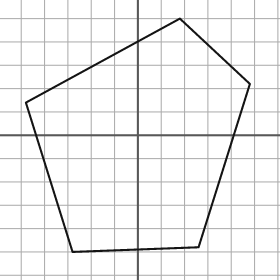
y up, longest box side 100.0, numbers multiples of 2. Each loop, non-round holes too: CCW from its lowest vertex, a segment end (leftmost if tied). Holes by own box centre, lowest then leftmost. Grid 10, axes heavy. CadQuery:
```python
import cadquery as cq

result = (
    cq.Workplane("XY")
    .moveTo(-28.0, -50.0)
    .lineTo(26.0, -48.0)
    .lineTo(48.0, 22.0)
    .lineTo(18.0, 50.0)
    .lineTo(-48.0, 14.0)
    .close()
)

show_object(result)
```